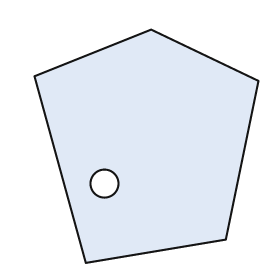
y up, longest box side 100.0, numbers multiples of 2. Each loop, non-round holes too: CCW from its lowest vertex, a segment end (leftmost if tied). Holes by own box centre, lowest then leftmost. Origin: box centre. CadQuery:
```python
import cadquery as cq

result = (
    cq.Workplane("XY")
    .moveTo(-26.0, -50.0)
    .lineTo(34.0, -40.0)
    .lineTo(48.0, 28.0)
    .lineTo(2.0, 50.0)
    .lineTo(-48.0, 30.0)
    .close()
    .moveTo(-18.0, -16.0)
    .circle(6.0)
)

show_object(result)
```